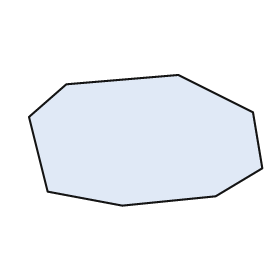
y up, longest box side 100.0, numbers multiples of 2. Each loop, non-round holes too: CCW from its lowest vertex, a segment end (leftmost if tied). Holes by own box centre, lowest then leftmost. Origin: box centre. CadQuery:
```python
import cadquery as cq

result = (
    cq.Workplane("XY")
    .moveTo(-10.0, -28.0)
    .lineTo(30.0, -24.0)
    .lineTo(50.0, -12.0)
    .lineTo(46.0, 12.0)
    .lineTo(14.0, 28.0)
    .lineTo(-34.0, 24.0)
    .lineTo(-50.0, 10.0)
    .lineTo(-42.0, -22.0)
    .close()
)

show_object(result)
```